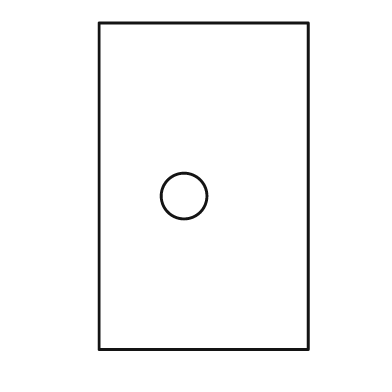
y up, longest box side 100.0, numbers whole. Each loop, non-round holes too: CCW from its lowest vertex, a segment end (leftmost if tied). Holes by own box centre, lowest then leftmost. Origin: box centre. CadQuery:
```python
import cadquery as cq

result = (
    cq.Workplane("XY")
    .moveTo(-32.0, -50.0)
    .lineTo(32.0, -50.0)
    .lineTo(32.0, 50.0)
    .lineTo(-32.0, 50.0)
    .close()
    .moveTo(-6.0, -3.0)
    .circle(7.0)
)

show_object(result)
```